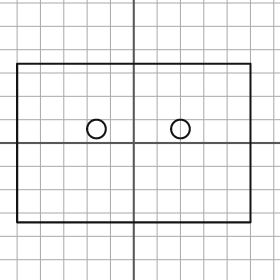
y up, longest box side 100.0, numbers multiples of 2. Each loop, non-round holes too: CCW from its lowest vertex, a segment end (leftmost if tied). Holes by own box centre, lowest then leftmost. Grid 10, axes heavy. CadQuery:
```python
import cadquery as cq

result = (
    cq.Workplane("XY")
    .moveTo(-50.0, -34.0)
    .lineTo(50.0, -34.0)
    .lineTo(50.0, 34.0)
    .lineTo(-50.0, 34.0)
    .close()
    .moveTo(-16.0, 6.0)
    .circle(4.0)
    .moveTo(20.0, 6.0)
    .circle(4.0)
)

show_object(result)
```